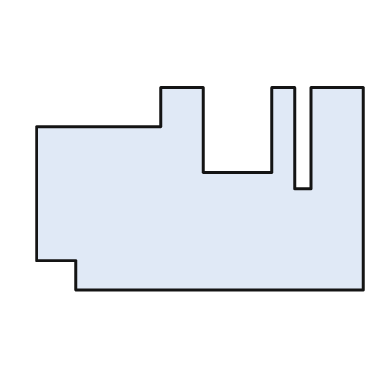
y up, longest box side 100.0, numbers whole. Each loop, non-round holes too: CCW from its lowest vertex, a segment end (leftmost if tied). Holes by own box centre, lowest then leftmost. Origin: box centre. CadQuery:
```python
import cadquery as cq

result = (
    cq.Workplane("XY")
    .moveTo(-38.0, -31.0)
    .lineTo(50.0, -31.0)
    .lineTo(50.0, 31.0)
    .lineTo(34.0, 31.0)
    .lineTo(34.0, 0.0)
    .lineTo(29.0, 0.0)
    .lineTo(29.0, 31.0)
    .lineTo(22.0, 31.0)
    .lineTo(22.0, 5.0)
    .lineTo(1.0, 5.0)
    .lineTo(1.0, 31.0)
    .lineTo(-12.0, 31.0)
    .lineTo(-12.0, 19.0)
    .lineTo(-50.0, 19.0)
    .lineTo(-50.0, -22.0)
    .lineTo(-38.0, -22.0)
    .close()
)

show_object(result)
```